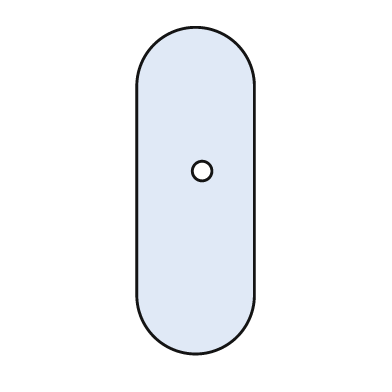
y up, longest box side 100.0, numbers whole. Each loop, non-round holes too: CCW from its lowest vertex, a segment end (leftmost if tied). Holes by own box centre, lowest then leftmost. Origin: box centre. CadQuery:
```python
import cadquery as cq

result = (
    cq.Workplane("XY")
    .moveTo(-18.0, -32.0)
    .threePointArc((0.0, -50.0), (18.0, -32.0))
    .lineTo(18.0, 32.0)
    .threePointArc((0.0, 50.0), (-18.0, 32.0))
    .close()
    .moveTo(2.0, 6.0)
    .circle(3.0)
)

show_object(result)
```